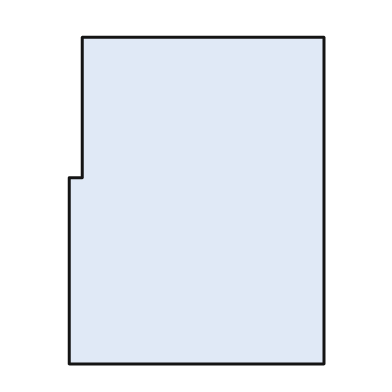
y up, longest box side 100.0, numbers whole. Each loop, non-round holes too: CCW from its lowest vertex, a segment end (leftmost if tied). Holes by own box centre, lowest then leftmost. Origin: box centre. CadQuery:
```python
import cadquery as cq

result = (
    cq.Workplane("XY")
    .moveTo(-39.0, -50.0)
    .lineTo(39.0, -50.0)
    .lineTo(39.0, 50.0)
    .lineTo(-35.0, 50.0)
    .lineTo(-35.0, 7.0)
    .lineTo(-39.0, 7.0)
    .close()
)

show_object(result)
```